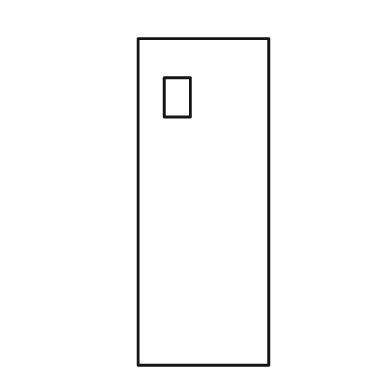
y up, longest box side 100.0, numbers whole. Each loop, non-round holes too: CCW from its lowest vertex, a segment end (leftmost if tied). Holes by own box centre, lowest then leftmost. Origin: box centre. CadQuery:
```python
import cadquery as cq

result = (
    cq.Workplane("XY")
    .moveTo(-20.0, -50.0)
    .lineTo(20.0, -50.0)
    .lineTo(20.0, 50.0)
    .lineTo(-20.0, 50.0)
    .close()
    .moveTo(-12.0, 26.0)
    .lineTo(-4.0, 26.0)
    .lineTo(-4.0, 38.0)
    .lineTo(-12.0, 38.0)
    .close()
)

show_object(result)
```